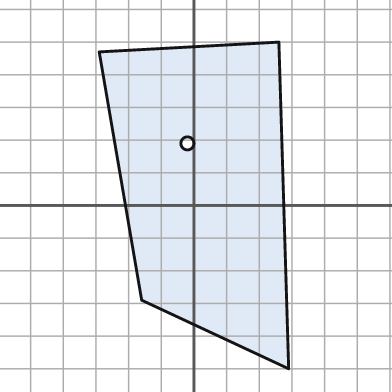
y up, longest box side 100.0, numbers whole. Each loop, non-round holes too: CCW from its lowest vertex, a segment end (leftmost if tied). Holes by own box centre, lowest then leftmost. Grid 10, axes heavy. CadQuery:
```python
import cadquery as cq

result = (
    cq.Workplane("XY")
    .moveTo(29.0, -50.0)
    .lineTo(26.0, 50.0)
    .lineTo(-29.0, 47.0)
    .lineTo(-16.0, -29.0)
    .close()
    .moveTo(-2.0, 19.0)
    .circle(2.0)
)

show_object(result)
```